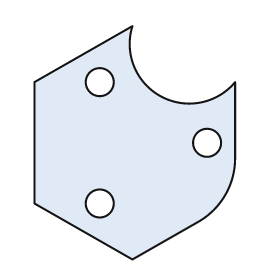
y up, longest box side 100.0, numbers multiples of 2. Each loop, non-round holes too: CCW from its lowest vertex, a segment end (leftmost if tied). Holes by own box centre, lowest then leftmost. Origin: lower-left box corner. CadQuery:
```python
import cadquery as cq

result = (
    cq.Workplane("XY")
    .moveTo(42.0, 0.0)
    .lineTo(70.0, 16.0)
    .threePointArc((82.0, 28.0), (86.0, 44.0))
    .lineTo(86.0, 76.0)
    .threePointArc((54.0, 70.0), (42.0, 100.0))
    .lineTo(0.0, 76.0)
    .lineTo(0.0, 24.0)
    .close()
    .moveTo(28.0, 24.0)
    .circle(6.0)
    .moveTo(74.0, 50.0)
    .circle(6.0)
    .moveTo(28.0, 76.0)
    .circle(6.0)
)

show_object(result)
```